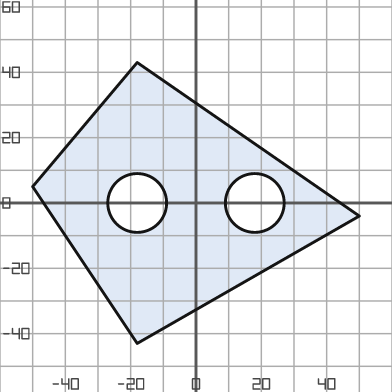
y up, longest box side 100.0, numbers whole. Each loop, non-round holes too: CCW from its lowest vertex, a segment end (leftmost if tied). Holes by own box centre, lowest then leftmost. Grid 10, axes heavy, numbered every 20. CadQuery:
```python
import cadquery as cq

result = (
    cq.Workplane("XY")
    .moveTo(-18.0, -43.0)
    .lineTo(50.0, -4.0)
    .lineTo(-18.0, 43.0)
    .lineTo(-50.0, 5.0)
    .close()
    .moveTo(-18.0, 0.0)
    .circle(9.0)
    .moveTo(18.0, 0.0)
    .circle(9.0)
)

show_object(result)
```